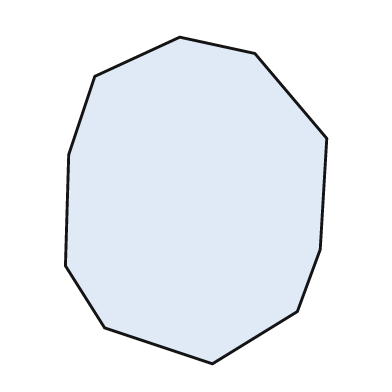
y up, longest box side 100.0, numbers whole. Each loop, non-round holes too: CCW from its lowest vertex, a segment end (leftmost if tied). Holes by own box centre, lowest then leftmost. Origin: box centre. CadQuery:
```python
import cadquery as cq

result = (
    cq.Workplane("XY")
    .moveTo(5.0, -50.0)
    .lineTo(31.0, -34.0)
    .lineTo(38.0, -15.0)
    .lineTo(40.0, 19.0)
    .lineTo(18.0, 45.0)
    .lineTo(-5.0, 50.0)
    .lineTo(-31.0, 38.0)
    .lineTo(-39.0, 14.0)
    .lineTo(-40.0, -20.0)
    .lineTo(-28.0, -39.0)
    .close()
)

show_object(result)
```